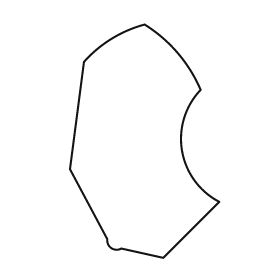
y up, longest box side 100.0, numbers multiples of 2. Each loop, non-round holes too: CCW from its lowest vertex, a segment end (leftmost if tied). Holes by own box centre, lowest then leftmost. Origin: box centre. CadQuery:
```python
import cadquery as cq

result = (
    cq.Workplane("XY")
    .moveTo(8.0, -50.0)
    .lineTo(32.0, -26.0)
    .threePointArc((16.0, -4.0), (24.0, 22.0))
    .threePointArc((14.0, 38.0), (0.0, 50.0))
    .threePointArc((-14.0, 44.0), (-26.0, 34.0))
    .lineTo(-32.0, -12.0)
    .lineTo(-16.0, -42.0)
    .threePointArc((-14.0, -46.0), (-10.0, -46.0))
    .close()
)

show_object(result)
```